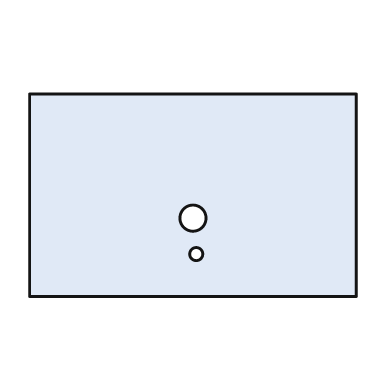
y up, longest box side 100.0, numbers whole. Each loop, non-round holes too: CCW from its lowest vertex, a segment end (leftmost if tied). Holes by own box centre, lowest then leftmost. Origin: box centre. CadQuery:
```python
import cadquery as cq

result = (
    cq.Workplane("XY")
    .moveTo(-50.0, -31.0)
    .lineTo(50.0, -31.0)
    .lineTo(50.0, 31.0)
    .lineTo(-50.0, 31.0)
    .close()
    .moveTo(1.0, -18.0)
    .circle(2.0)
    .moveTo(0.0, -7.0)
    .circle(4.0)
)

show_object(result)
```